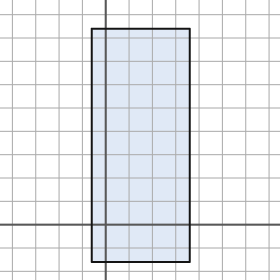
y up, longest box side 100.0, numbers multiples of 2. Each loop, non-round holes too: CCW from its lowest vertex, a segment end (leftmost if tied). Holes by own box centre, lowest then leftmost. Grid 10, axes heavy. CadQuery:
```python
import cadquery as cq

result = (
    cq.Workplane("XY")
    .moveTo(-6.0, -16.0)
    .lineTo(36.0, -16.0)
    .lineTo(36.0, 84.0)
    .lineTo(-6.0, 84.0)
    .close()
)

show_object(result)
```